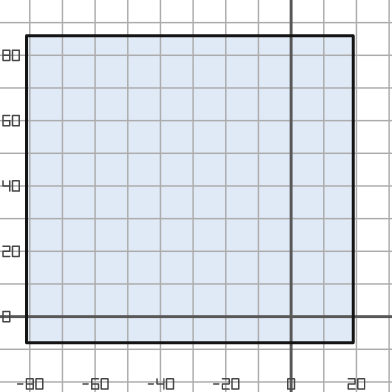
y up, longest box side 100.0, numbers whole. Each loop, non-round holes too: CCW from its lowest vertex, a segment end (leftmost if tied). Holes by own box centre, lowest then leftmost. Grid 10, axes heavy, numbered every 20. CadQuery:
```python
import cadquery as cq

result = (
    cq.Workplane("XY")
    .moveTo(-81.0, -8.0)
    .lineTo(19.0, -8.0)
    .lineTo(19.0, 86.0)
    .lineTo(-81.0, 86.0)
    .close()
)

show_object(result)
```